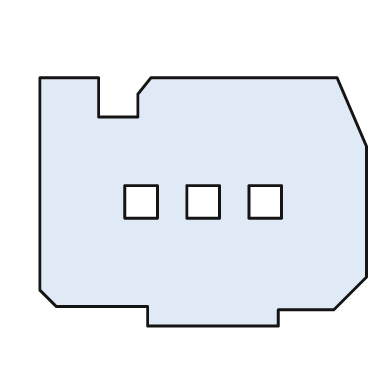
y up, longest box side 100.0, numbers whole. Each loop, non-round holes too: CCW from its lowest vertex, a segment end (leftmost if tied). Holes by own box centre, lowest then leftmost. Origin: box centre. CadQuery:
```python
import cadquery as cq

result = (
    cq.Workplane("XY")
    .moveTo(-17.0, -38.0)
    .lineTo(23.0, -38.0)
    .lineTo(23.0, -33.0)
    .lineTo(40.0, -33.0)
    .lineTo(50.0, -23.0)
    .lineTo(50.0, 17.0)
    .lineTo(41.0, 38.0)
    .lineTo(-16.0, 38.0)
    .lineTo(-20.0, 33.0)
    .lineTo(-20.0, 26.0)
    .lineTo(-32.0, 26.0)
    .lineTo(-32.0, 38.0)
    .lineTo(-50.0, 38.0)
    .lineTo(-50.0, -27.0)
    .lineTo(-45.0, -32.0)
    .lineTo(-17.0, -32.0)
    .close()
    .moveTo(-24.0, -5.0)
    .lineTo(-14.0, -5.0)
    .lineTo(-14.0, 5.0)
    .lineTo(-24.0, 5.0)
    .close()
    .moveTo(-5.0, -5.0)
    .lineTo(5.0, -5.0)
    .lineTo(5.0, 5.0)
    .lineTo(-5.0, 5.0)
    .close()
    .moveTo(14.0, -5.0)
    .lineTo(24.0, -5.0)
    .lineTo(24.0, 5.0)
    .lineTo(14.0, 5.0)
    .close()
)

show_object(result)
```